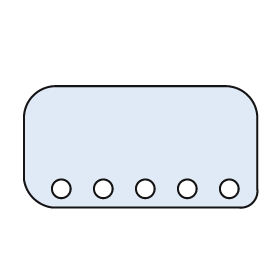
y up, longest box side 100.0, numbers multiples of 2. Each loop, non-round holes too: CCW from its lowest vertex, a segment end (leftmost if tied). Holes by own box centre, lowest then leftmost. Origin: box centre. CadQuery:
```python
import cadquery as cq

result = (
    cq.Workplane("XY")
    .moveTo(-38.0, -26.0)
    .lineTo(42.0, -26.0)
    .threePointArc((48.0, -24.0), (50.0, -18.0))
    .lineTo(50.0, 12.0)
    .threePointArc((46.0, 22.0), (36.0, 26.0))
    .lineTo(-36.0, 26.0)
    .threePointArc((-46.0, 22.0), (-50.0, 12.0))
    .lineTo(-50.0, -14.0)
    .threePointArc((-46.0, -22.0), (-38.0, -26.0))
    .close()
    .moveTo(-34.0, -18.0)
    .circle(4.0)
    .moveTo(-16.0, -18.0)
    .circle(4.0)
    .moveTo(2.0, -18.0)
    .circle(4.0)
    .moveTo(20.0, -18.0)
    .circle(4.0)
    .moveTo(38.0, -18.0)
    .circle(4.0)
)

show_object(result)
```